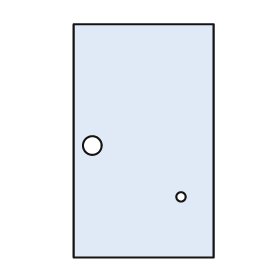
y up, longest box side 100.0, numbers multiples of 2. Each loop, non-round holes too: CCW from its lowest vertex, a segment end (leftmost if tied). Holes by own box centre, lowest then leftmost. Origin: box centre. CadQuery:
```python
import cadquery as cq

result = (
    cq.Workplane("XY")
    .moveTo(-30.0, -50.0)
    .lineTo(30.0, -50.0)
    .lineTo(30.0, 50.0)
    .lineTo(-30.0, 50.0)
    .close()
    .moveTo(16.0, -24.0)
    .circle(2.0)
    .moveTo(-22.0, -2.0)
    .circle(4.0)
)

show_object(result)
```